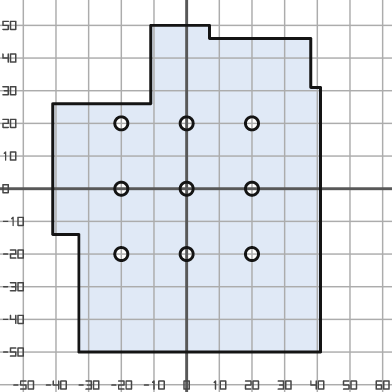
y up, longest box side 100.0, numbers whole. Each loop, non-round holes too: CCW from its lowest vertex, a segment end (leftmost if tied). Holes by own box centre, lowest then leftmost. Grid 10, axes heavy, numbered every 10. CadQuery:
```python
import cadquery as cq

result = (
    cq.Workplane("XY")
    .moveTo(-33.0, -50.0)
    .lineTo(41.0, -50.0)
    .lineTo(41.0, 31.0)
    .lineTo(38.0, 31.0)
    .lineTo(38.0, 46.0)
    .lineTo(7.0, 46.0)
    .lineTo(7.0, 50.0)
    .lineTo(-11.0, 50.0)
    .lineTo(-11.0, 26.0)
    .lineTo(-41.0, 26.0)
    .lineTo(-41.0, -14.0)
    .lineTo(-33.0, -14.0)
    .close()
    .moveTo(-20.0, -20.0)
    .circle(2.0)
    .moveTo(0.0, -20.0)
    .circle(2.0)
    .moveTo(20.0, -20.0)
    .circle(2.0)
    .moveTo(-20.0, 0.0)
    .circle(2.0)
    .moveTo(0.0, 0.0)
    .circle(2.0)
    .moveTo(20.0, 0.0)
    .circle(2.0)
    .moveTo(-20.0, 20.0)
    .circle(2.0)
    .moveTo(0.0, 20.0)
    .circle(2.0)
    .moveTo(20.0, 20.0)
    .circle(2.0)
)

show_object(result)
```